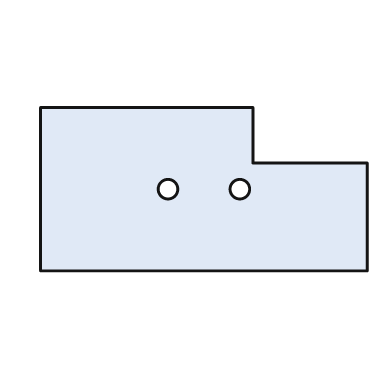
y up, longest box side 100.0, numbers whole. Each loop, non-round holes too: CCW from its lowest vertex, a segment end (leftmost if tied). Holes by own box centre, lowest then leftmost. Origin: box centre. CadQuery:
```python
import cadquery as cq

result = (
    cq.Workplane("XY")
    .moveTo(-50.0, -25.0)
    .lineTo(50.0, -25.0)
    .lineTo(50.0, 8.0)
    .lineTo(15.0, 8.0)
    .lineTo(15.0, 25.0)
    .lineTo(-50.0, 25.0)
    .close()
    .moveTo(-11.0, 0.0)
    .circle(3.0)
    .moveTo(11.0, 0.0)
    .circle(3.0)
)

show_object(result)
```